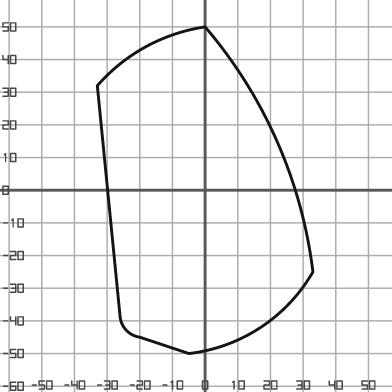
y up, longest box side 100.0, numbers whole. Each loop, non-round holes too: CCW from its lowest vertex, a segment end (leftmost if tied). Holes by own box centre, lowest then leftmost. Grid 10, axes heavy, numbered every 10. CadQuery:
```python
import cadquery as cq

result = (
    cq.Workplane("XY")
    .moveTo(-5.0, -50.0)
    .threePointArc((17.0, -42.0), (33.0, -25.0))
    .threePointArc((22.0, 15.0), (0.0, 50.0))
    .threePointArc((-18.0, 44.0), (-33.0, 32.0))
    .lineTo(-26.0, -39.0)
    .threePointArc((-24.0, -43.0), (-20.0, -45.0))
    .close()
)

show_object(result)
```